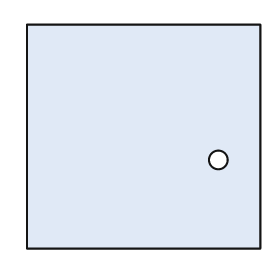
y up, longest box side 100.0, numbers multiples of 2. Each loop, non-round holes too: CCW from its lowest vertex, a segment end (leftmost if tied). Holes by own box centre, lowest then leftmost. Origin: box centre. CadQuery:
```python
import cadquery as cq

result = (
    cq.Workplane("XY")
    .moveTo(-50.0, -48.0)
    .lineTo(50.0, -48.0)
    .lineTo(50.0, 48.0)
    .lineTo(-50.0, 48.0)
    .close()
    .moveTo(32.0, -10.0)
    .circle(4.0)
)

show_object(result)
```